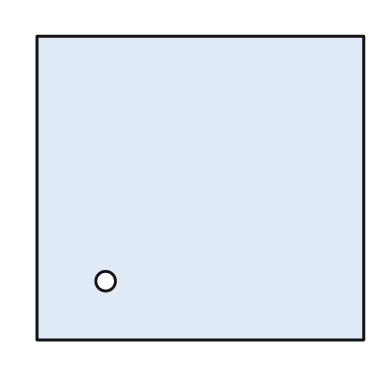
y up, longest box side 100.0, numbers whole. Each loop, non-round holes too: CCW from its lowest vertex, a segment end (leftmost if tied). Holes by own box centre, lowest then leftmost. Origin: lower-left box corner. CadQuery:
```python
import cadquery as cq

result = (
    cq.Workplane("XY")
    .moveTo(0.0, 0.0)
    .lineTo(100.0, 0.0)
    .lineTo(100.0, 93.0)
    .lineTo(0.0, 93.0)
    .close()
    .moveTo(21.0, 18.0)
    .circle(3.0)
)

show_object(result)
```